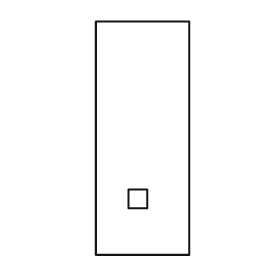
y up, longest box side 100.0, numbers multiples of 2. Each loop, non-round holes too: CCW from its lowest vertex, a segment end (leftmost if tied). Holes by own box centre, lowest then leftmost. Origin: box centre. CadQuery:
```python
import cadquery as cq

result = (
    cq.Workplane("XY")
    .moveTo(-20.0, -50.0)
    .lineTo(20.0, -50.0)
    .lineTo(20.0, 50.0)
    .lineTo(-20.0, 50.0)
    .close()
    .moveTo(-6.0, -30.0)
    .lineTo(2.0, -30.0)
    .lineTo(2.0, -22.0)
    .lineTo(-6.0, -22.0)
    .close()
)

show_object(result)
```